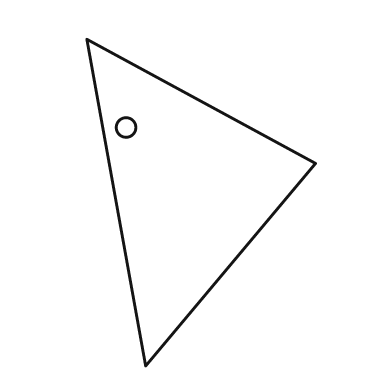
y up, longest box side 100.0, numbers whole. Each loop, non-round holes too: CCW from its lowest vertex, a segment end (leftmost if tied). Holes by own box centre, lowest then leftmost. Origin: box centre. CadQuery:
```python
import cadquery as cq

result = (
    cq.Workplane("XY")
    .moveTo(-17.0, -50.0)
    .lineTo(35.0, 12.0)
    .lineTo(-35.0, 50.0)
    .close()
    .moveTo(-23.0, 23.0)
    .circle(3.0)
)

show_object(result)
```